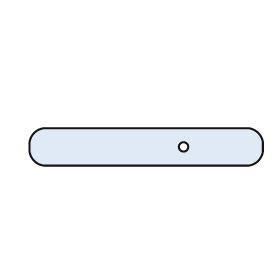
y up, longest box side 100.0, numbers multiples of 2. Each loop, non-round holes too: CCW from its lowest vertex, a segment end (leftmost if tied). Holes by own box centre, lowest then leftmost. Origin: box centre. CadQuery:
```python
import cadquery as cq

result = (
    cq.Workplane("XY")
    .moveTo(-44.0, -8.0)
    .lineTo(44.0, -8.0)
    .threePointArc((48.0, -6.0), (50.0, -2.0))
    .lineTo(50.0, 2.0)
    .threePointArc((48.0, 6.0), (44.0, 8.0))
    .lineTo(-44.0, 8.0)
    .threePointArc((-48.0, 6.0), (-50.0, 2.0))
    .lineTo(-50.0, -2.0)
    .threePointArc((-48.0, -6.0), (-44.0, -8.0))
    .close()
    .moveTo(16.0, 0.0)
    .circle(2.0)
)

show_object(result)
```